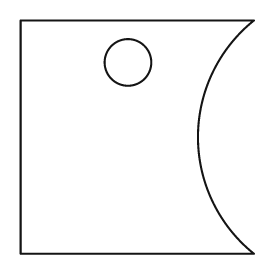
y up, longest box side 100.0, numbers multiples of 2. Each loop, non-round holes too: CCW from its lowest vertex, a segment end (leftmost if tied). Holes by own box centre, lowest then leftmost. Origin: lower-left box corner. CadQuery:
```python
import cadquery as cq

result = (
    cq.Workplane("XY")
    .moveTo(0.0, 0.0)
    .lineTo(100.0, 0.0)
    .threePointArc((76.0, 50.0), (100.0, 100.0))
    .lineTo(0.0, 100.0)
    .close()
    .moveTo(46.0, 82.0)
    .circle(10.0)
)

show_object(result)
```